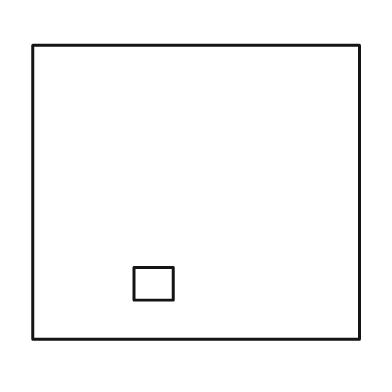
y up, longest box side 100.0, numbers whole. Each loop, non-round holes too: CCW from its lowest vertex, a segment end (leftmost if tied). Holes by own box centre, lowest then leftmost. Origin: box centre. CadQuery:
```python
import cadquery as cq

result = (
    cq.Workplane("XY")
    .moveTo(-50.0, -45.0)
    .lineTo(50.0, -45.0)
    .lineTo(50.0, 45.0)
    .lineTo(-50.0, 45.0)
    .close()
    .moveTo(-19.0, -33.0)
    .lineTo(-7.0, -33.0)
    .lineTo(-7.0, -23.0)
    .lineTo(-19.0, -23.0)
    .close()
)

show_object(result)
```